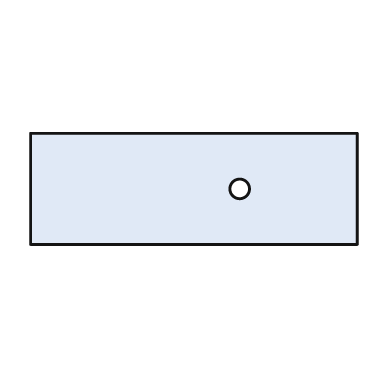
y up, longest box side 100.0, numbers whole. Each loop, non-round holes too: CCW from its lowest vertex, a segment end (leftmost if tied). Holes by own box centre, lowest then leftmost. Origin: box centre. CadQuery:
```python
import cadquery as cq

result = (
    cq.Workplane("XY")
    .moveTo(-50.0, -17.0)
    .lineTo(50.0, -17.0)
    .lineTo(50.0, 17.0)
    .lineTo(-50.0, 17.0)
    .close()
    .moveTo(14.0, 0.0)
    .circle(3.0)
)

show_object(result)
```